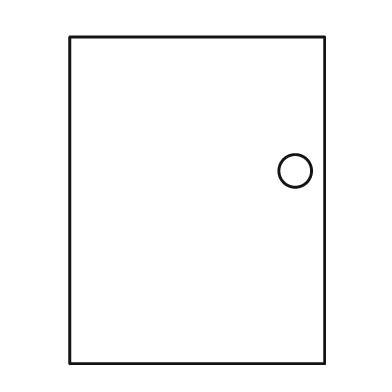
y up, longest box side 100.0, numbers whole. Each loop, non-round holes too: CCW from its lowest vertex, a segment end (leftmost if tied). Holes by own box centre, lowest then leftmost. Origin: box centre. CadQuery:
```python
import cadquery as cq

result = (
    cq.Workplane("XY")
    .moveTo(-39.0, -50.0)
    .lineTo(39.0, -50.0)
    .lineTo(39.0, 50.0)
    .lineTo(-39.0, 50.0)
    .close()
    .moveTo(30.0, 9.0)
    .circle(5.0)
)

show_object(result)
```